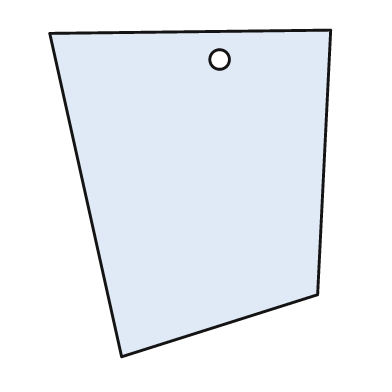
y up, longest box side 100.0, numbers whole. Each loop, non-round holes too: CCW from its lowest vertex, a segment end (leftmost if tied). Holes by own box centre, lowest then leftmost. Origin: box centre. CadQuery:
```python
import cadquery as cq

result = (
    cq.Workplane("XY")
    .moveTo(-21.0, -50.0)
    .lineTo(39.0, -31.0)
    .lineTo(43.0, 50.0)
    .lineTo(-43.0, 49.0)
    .close()
    .moveTo(9.0, 41.0)
    .circle(3.0)
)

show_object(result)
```